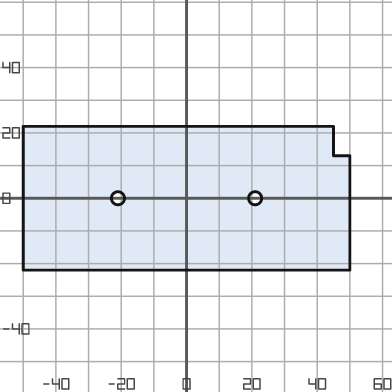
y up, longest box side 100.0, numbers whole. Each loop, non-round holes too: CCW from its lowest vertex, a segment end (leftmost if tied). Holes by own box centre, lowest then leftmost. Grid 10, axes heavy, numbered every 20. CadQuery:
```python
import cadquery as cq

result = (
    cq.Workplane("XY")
    .moveTo(-50.0, -22.0)
    .lineTo(50.0, -22.0)
    .lineTo(50.0, 13.0)
    .lineTo(45.0, 13.0)
    .lineTo(45.0, 22.0)
    .lineTo(-50.0, 22.0)
    .close()
    .moveTo(-21.0, 0.0)
    .circle(2.0)
    .moveTo(21.0, 0.0)
    .circle(2.0)
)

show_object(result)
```